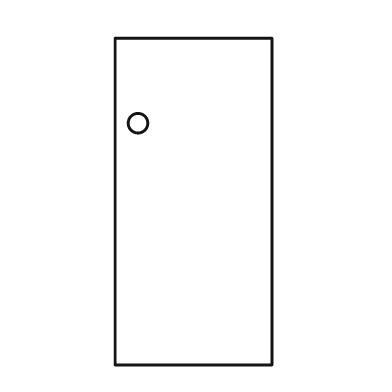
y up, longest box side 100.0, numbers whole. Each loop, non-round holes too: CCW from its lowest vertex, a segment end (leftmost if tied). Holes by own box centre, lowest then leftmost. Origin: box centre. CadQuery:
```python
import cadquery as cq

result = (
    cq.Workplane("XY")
    .moveTo(-24.0, -50.0)
    .lineTo(24.0, -50.0)
    .lineTo(24.0, 50.0)
    .lineTo(-24.0, 50.0)
    .close()
    .moveTo(-17.0, 24.0)
    .circle(3.0)
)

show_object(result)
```